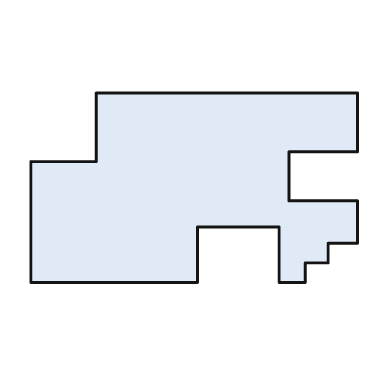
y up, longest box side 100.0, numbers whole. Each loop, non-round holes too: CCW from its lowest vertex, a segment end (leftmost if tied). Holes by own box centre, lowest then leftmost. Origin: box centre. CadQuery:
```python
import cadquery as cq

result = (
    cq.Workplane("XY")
    .moveTo(-50.0, -29.0)
    .lineTo(1.0, -29.0)
    .lineTo(1.0, -12.0)
    .lineTo(26.0, -12.0)
    .lineTo(26.0, -29.0)
    .lineTo(34.0, -29.0)
    .lineTo(34.0, -23.0)
    .lineTo(41.0, -23.0)
    .lineTo(41.0, -17.0)
    .lineTo(50.0, -17.0)
    .lineTo(50.0, -4.0)
    .lineTo(29.0, -4.0)
    .lineTo(29.0, 11.0)
    .lineTo(50.0, 11.0)
    .lineTo(50.0, 29.0)
    .lineTo(-30.0, 29.0)
    .lineTo(-30.0, 8.0)
    .lineTo(-50.0, 8.0)
    .close()
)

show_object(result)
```